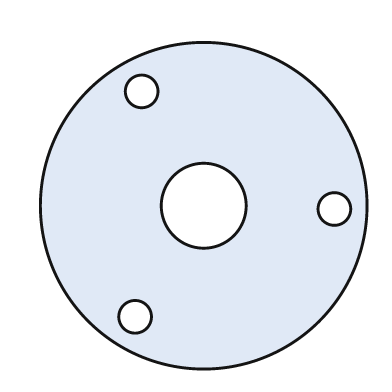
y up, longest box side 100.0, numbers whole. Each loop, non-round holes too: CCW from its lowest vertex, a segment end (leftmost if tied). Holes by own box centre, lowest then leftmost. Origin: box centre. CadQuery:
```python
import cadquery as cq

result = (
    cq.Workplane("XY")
    .moveTo(0.0, 0.0)
    .circle(50.0)
    .moveTo(-21.0, -34.0)
    .circle(5.0)
    .moveTo(40.0, -1.0)
    .circle(5.0)
    .moveTo(0.0, 0.0)
    .circle(13.0)
    .moveTo(-19.0, 35.0)
    .circle(5.0)
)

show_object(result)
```